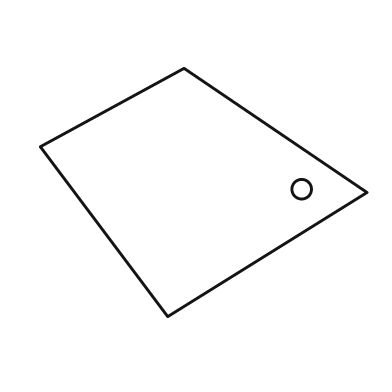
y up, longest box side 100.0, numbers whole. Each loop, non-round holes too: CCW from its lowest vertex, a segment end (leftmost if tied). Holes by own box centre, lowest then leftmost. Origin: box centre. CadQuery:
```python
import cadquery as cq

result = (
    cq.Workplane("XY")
    .moveTo(-11.0, -38.0)
    .lineTo(50.0, 0.0)
    .lineTo(-6.0, 38.0)
    .lineTo(-50.0, 14.0)
    .close()
    .moveTo(30.0, 1.0)
    .circle(3.0)
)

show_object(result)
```